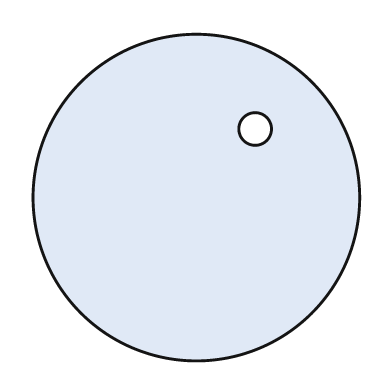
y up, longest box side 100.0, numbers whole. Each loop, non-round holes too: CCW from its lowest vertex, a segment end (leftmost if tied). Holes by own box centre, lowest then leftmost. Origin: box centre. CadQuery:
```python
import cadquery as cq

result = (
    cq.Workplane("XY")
    .moveTo(0.0, 0.0)
    .circle(50.0)
    .moveTo(18.0, 21.0)
    .circle(5.0)
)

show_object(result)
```